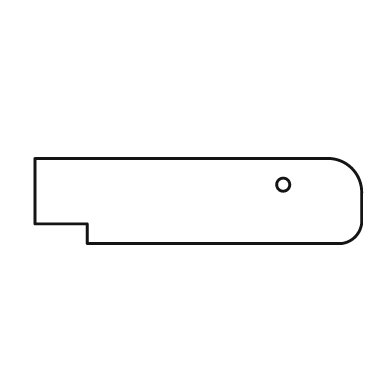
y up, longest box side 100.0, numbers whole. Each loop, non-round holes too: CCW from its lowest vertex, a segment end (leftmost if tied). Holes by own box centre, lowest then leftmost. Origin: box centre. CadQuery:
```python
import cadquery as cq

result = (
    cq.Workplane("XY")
    .moveTo(-34.0, -13.0)
    .lineTo(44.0, -13.0)
    .threePointArc((48.0, -11.0), (50.0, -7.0))
    .lineTo(50.0, 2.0)
    .threePointArc((47.0, 10.0), (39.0, 13.0))
    .lineTo(-50.0, 13.0)
    .lineTo(-50.0, -7.0)
    .lineTo(-34.0, -7.0)
    .close()
    .moveTo(26.0, 5.0)
    .circle(2.0)
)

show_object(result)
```